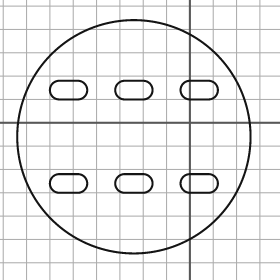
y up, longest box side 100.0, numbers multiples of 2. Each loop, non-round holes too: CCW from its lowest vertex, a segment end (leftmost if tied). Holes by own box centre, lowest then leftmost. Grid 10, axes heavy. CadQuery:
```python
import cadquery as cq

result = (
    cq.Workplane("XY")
    .moveTo(-24.0, -6.0)
    .circle(50.0)
    .moveTo(-56.0, -30.0)
    .lineTo(-48.0, -30.0)
    .threePointArc((-44.0, -26.0), (-48.0, -22.0))
    .lineTo(-56.0, -22.0)
    .threePointArc((-60.0, -26.0), (-56.0, -30.0))
    .close()
    .moveTo(-28.0, -30.0)
    .lineTo(-20.0, -30.0)
    .threePointArc((-16.0, -26.0), (-20.0, -22.0))
    .lineTo(-28.0, -22.0)
    .threePointArc((-32.0, -26.0), (-28.0, -30.0))
    .close()
    .moveTo(0.0, -30.0)
    .lineTo(8.0, -30.0)
    .threePointArc((12.0, -26.0), (8.0, -22.0))
    .lineTo(0.0, -22.0)
    .threePointArc((-4.0, -26.0), (0.0, -30.0))
    .close()
    .moveTo(-56.0, 10.0)
    .lineTo(-48.0, 10.0)
    .threePointArc((-44.0, 14.0), (-48.0, 18.0))
    .lineTo(-56.0, 18.0)
    .threePointArc((-60.0, 14.0), (-56.0, 10.0))
    .close()
    .moveTo(-28.0, 10.0)
    .lineTo(-20.0, 10.0)
    .threePointArc((-16.0, 14.0), (-20.0, 18.0))
    .lineTo(-28.0, 18.0)
    .threePointArc((-32.0, 14.0), (-28.0, 10.0))
    .close()
    .moveTo(0.0, 10.0)
    .lineTo(8.0, 10.0)
    .threePointArc((12.0, 14.0), (8.0, 18.0))
    .lineTo(0.0, 18.0)
    .threePointArc((-4.0, 14.0), (0.0, 10.0))
    .close()
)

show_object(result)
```